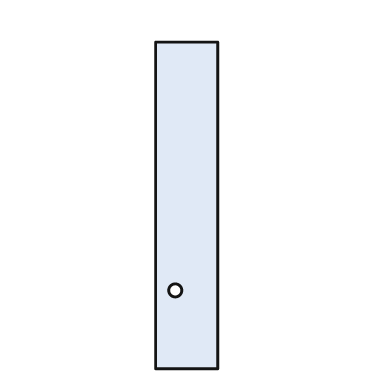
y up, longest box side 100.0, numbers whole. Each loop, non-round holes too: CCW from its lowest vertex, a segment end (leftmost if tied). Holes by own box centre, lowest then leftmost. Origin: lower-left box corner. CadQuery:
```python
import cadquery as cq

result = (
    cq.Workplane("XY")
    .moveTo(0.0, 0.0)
    .lineTo(19.0, 0.0)
    .lineTo(19.0, 100.0)
    .lineTo(0.0, 100.0)
    .close()
    .moveTo(6.0, 24.0)
    .circle(2.0)
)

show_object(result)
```